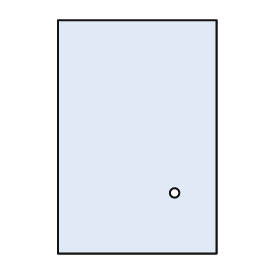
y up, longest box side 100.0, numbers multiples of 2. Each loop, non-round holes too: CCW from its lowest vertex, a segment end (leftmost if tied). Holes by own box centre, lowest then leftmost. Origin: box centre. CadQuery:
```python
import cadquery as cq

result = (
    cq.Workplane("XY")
    .moveTo(-34.0, -50.0)
    .lineTo(34.0, -50.0)
    .lineTo(34.0, 50.0)
    .lineTo(-34.0, 50.0)
    .close()
    .moveTo(16.0, -24.0)
    .circle(2.0)
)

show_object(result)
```